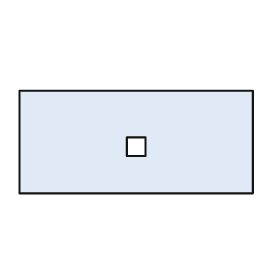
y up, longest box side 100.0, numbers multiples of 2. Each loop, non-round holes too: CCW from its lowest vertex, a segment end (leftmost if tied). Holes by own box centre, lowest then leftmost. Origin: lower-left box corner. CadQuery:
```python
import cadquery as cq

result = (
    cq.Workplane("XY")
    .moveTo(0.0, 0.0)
    .lineTo(100.0, 0.0)
    .lineTo(100.0, 44.0)
    .lineTo(0.0, 44.0)
    .close()
    .moveTo(46.0, 16.0)
    .lineTo(54.0, 16.0)
    .lineTo(54.0, 24.0)
    .lineTo(46.0, 24.0)
    .close()
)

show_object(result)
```